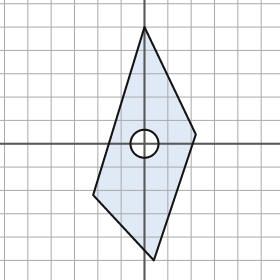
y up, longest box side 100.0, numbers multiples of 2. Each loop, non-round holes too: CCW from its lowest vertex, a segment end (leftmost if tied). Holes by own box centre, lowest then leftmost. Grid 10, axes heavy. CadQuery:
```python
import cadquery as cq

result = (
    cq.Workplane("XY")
    .moveTo(4.0, -50.0)
    .lineTo(22.0, 4.0)
    .lineTo(0.0, 50.0)
    .lineTo(-22.0, -22.0)
    .close()
    .moveTo(0.0, 0.0)
    .circle(6.0)
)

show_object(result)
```